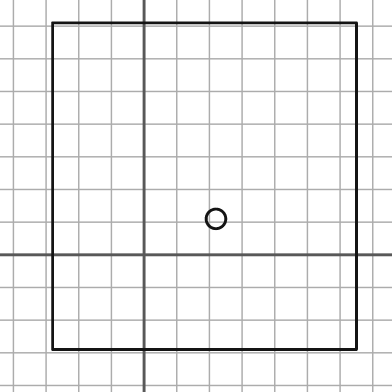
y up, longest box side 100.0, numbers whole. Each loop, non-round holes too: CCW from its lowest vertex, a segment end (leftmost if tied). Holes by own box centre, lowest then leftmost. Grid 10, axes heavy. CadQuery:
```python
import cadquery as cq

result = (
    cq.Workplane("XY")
    .moveTo(-28.0, -29.0)
    .lineTo(65.0, -29.0)
    .lineTo(65.0, 71.0)
    .lineTo(-28.0, 71.0)
    .close()
    .moveTo(22.0, 11.0)
    .circle(3.0)
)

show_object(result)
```